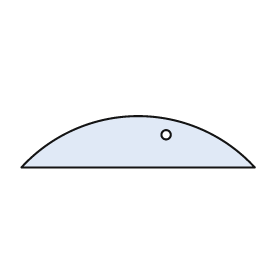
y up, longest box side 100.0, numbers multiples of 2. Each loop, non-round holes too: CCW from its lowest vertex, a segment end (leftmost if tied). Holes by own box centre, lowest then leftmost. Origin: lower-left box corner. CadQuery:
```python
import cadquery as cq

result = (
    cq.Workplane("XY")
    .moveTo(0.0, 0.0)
    .lineTo(100.0, 0.0)
    .threePointArc((50.0, 22.0), (0.0, 0.0))
    .close()
    .moveTo(62.0, 14.0)
    .circle(2.0)
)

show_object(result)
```